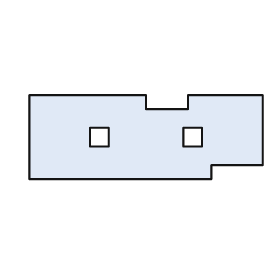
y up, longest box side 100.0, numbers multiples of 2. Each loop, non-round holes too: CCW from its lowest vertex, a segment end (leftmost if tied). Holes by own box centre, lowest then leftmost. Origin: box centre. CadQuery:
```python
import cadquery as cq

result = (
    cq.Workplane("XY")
    .moveTo(-50.0, -18.0)
    .lineTo(28.0, -18.0)
    .lineTo(28.0, -12.0)
    .lineTo(50.0, -12.0)
    .lineTo(50.0, 18.0)
    .lineTo(18.0, 18.0)
    .lineTo(18.0, 12.0)
    .lineTo(0.0, 12.0)
    .lineTo(0.0, 18.0)
    .lineTo(-50.0, 18.0)
    .close()
    .moveTo(-24.0, -4.0)
    .lineTo(-16.0, -4.0)
    .lineTo(-16.0, 4.0)
    .lineTo(-24.0, 4.0)
    .close()
    .moveTo(16.0, -4.0)
    .lineTo(24.0, -4.0)
    .lineTo(24.0, 4.0)
    .lineTo(16.0, 4.0)
    .close()
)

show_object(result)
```